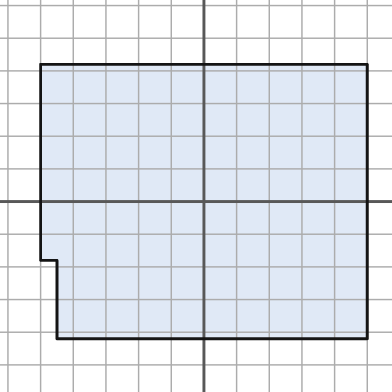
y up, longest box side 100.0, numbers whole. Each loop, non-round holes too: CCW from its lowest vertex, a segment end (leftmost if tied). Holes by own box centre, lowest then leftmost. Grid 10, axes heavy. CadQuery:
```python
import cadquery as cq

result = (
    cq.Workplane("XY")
    .moveTo(-45.0, -42.0)
    .lineTo(50.0, -42.0)
    .lineTo(50.0, 42.0)
    .lineTo(-50.0, 42.0)
    .lineTo(-50.0, -18.0)
    .lineTo(-45.0, -18.0)
    .close()
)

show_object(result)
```